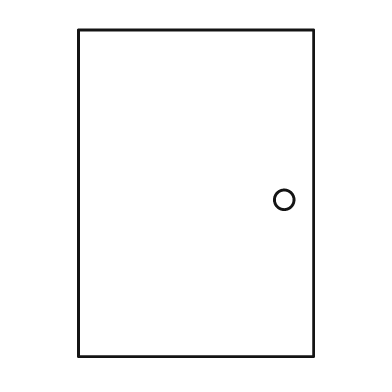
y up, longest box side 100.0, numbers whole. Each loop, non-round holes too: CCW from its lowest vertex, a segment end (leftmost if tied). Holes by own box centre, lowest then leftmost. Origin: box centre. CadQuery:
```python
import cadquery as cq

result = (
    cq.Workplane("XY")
    .moveTo(-36.0, -50.0)
    .lineTo(36.0, -50.0)
    .lineTo(36.0, 50.0)
    .lineTo(-36.0, 50.0)
    .close()
    .moveTo(27.0, -2.0)
    .circle(3.0)
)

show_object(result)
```